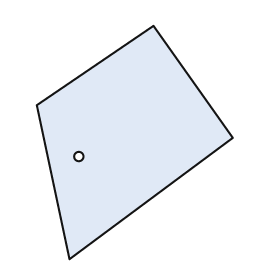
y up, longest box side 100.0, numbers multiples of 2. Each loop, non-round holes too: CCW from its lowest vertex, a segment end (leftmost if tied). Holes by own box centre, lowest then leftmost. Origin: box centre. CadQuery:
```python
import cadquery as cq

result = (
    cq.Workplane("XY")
    .moveTo(-28.0, -50.0)
    .lineTo(42.0, 2.0)
    .lineTo(8.0, 50.0)
    .lineTo(-42.0, 16.0)
    .close()
    .moveTo(-24.0, -6.0)
    .circle(2.0)
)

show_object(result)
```